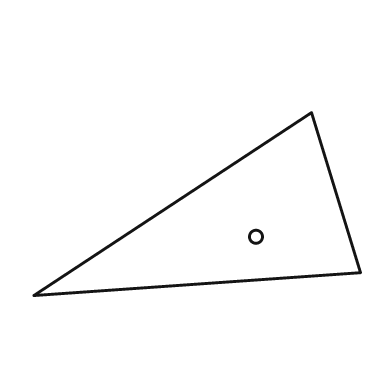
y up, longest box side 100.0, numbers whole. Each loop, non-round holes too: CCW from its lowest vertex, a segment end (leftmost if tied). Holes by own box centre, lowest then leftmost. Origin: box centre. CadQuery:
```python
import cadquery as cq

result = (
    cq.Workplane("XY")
    .moveTo(-50.0, -28.0)
    .lineTo(50.0, -21.0)
    .lineTo(35.0, 28.0)
    .close()
    .moveTo(18.0, -10.0)
    .circle(2.0)
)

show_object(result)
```